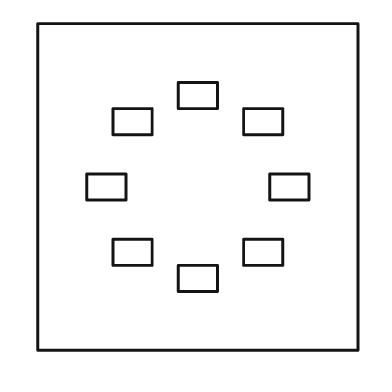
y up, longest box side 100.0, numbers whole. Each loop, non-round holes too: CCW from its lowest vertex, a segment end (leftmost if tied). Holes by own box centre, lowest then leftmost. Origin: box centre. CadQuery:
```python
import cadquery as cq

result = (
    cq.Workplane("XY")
    .moveTo(-49.0, -50.0)
    .lineTo(49.0, -50.0)
    .lineTo(49.0, 50.0)
    .lineTo(-49.0, 50.0)
    .close()
    .moveTo(-6.0, -32.0)
    .lineTo(6.0, -32.0)
    .lineTo(6.0, -24.0)
    .lineTo(-6.0, -24.0)
    .close()
    .moveTo(-26.0, -24.0)
    .lineTo(-14.0, -24.0)
    .lineTo(-14.0, -16.0)
    .lineTo(-26.0, -16.0)
    .close()
    .moveTo(14.0, -24.0)
    .lineTo(26.0, -24.0)
    .lineTo(26.0, -16.0)
    .lineTo(14.0, -16.0)
    .close()
    .moveTo(-34.0, -4.0)
    .lineTo(-22.0, -4.0)
    .lineTo(-22.0, 4.0)
    .lineTo(-34.0, 4.0)
    .close()
    .moveTo(22.0, -4.0)
    .lineTo(34.0, -4.0)
    .lineTo(34.0, 4.0)
    .lineTo(22.0, 4.0)
    .close()
    .moveTo(-26.0, 16.0)
    .lineTo(-14.0, 16.0)
    .lineTo(-14.0, 24.0)
    .lineTo(-26.0, 24.0)
    .close()
    .moveTo(14.0, 16.0)
    .lineTo(26.0, 16.0)
    .lineTo(26.0, 24.0)
    .lineTo(14.0, 24.0)
    .close()
    .moveTo(-6.0, 24.0)
    .lineTo(6.0, 24.0)
    .lineTo(6.0, 32.0)
    .lineTo(-6.0, 32.0)
    .close()
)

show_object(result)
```